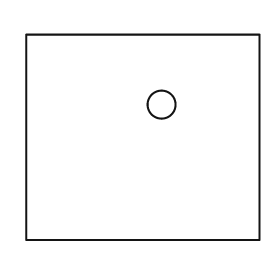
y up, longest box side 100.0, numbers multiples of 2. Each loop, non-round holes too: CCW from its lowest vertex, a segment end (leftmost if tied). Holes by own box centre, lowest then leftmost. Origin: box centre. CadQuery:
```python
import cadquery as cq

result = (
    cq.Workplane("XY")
    .moveTo(-50.0, -44.0)
    .lineTo(50.0, -44.0)
    .lineTo(50.0, 44.0)
    .lineTo(-50.0, 44.0)
    .close()
    .moveTo(8.0, 14.0)
    .circle(6.0)
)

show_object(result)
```